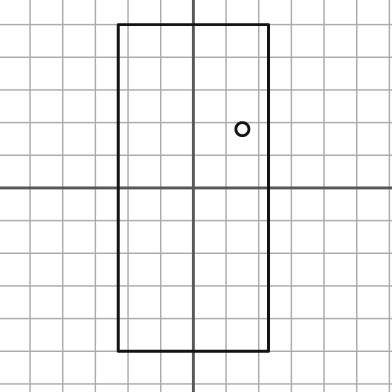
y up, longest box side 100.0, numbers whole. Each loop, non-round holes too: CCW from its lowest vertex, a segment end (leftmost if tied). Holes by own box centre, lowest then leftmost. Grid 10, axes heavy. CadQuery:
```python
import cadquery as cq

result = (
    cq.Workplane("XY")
    .moveTo(-23.0, -50.0)
    .lineTo(23.0, -50.0)
    .lineTo(23.0, 50.0)
    .lineTo(-23.0, 50.0)
    .close()
    .moveTo(15.0, 18.0)
    .circle(2.0)
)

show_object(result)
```